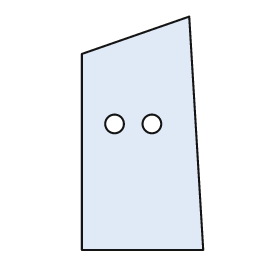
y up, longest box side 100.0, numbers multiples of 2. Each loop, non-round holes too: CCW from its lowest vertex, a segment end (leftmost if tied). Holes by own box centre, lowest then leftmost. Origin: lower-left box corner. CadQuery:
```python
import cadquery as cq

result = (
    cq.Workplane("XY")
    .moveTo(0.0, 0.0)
    .lineTo(52.0, 0.0)
    .lineTo(46.0, 100.0)
    .lineTo(0.0, 84.0)
    .close()
    .moveTo(14.0, 54.0)
    .circle(4.0)
    .moveTo(30.0, 54.0)
    .circle(4.0)
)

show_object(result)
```